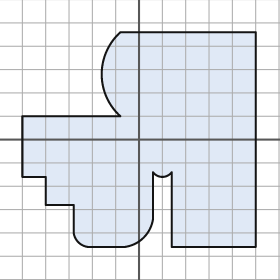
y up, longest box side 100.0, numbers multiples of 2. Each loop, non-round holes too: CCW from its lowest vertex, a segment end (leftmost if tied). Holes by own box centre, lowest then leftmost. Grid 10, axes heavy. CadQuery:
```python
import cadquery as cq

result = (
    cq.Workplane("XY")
    .moveTo(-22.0, -46.0)
    .lineTo(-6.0, -46.0)
    .threePointArc((2.0, -42.0), (6.0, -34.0))
    .lineTo(6.0, -14.0)
    .threePointArc((10.0, -16.0), (14.0, -14.0))
    .lineTo(14.0, -46.0)
    .lineTo(50.0, -46.0)
    .lineTo(50.0, 46.0)
    .lineTo(-8.0, 46.0)
    .threePointArc((-16.0, 28.0), (-8.0, 10.0))
    .lineTo(-50.0, 10.0)
    .lineTo(-50.0, -16.0)
    .lineTo(-40.0, -16.0)
    .lineTo(-40.0, -28.0)
    .lineTo(-28.0, -28.0)
    .lineTo(-28.0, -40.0)
    .threePointArc((-26.0, -44.0), (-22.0, -46.0))
    .close()
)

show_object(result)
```